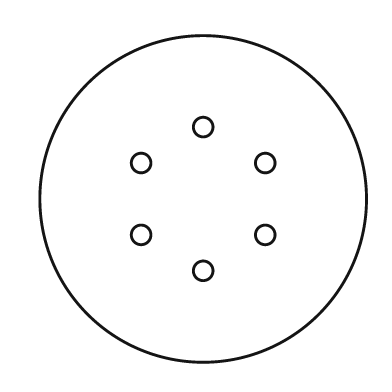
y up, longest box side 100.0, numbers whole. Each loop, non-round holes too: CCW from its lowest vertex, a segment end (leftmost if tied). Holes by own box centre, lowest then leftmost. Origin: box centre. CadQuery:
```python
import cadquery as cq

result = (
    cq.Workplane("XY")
    .moveTo(0.0, 0.0)
    .circle(50.0)
    .moveTo(0.0, -22.0)
    .circle(3.0)
    .moveTo(-19.0, -11.0)
    .circle(3.0)
    .moveTo(19.0, -11.0)
    .circle(3.0)
    .moveTo(-19.0, 11.0)
    .circle(3.0)
    .moveTo(19.0, 11.0)
    .circle(3.0)
    .moveTo(0.0, 22.0)
    .circle(3.0)
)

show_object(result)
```